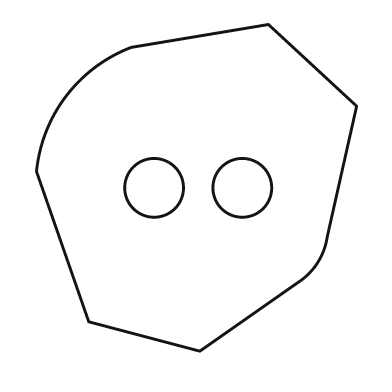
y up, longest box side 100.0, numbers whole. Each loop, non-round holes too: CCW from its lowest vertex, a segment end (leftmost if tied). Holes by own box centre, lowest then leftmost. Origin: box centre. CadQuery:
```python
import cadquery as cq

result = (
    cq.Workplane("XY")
    .moveTo(1.0, -50.0)
    .lineTo(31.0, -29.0)
    .threePointArc((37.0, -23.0), (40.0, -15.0))
    .lineTo(49.0, 25.0)
    .lineTo(22.0, 50.0)
    .lineTo(-20.0, 43.0)
    .threePointArc((-40.0, 28.0), (-49.0, 5.0))
    .lineTo(-33.0, -41.0)
    .close()
    .moveTo(-13.0, 0.0)
    .circle(9.0)
    .moveTo(14.0, 0.0)
    .circle(9.0)
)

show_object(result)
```